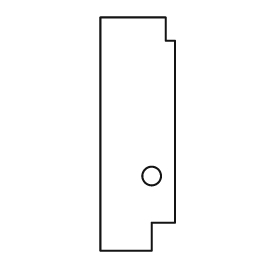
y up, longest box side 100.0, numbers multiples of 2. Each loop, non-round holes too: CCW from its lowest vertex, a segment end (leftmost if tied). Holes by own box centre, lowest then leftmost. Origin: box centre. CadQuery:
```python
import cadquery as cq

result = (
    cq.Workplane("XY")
    .moveTo(-16.0, -50.0)
    .lineTo(6.0, -50.0)
    .lineTo(6.0, -38.0)
    .lineTo(16.0, -38.0)
    .lineTo(16.0, 40.0)
    .lineTo(12.0, 40.0)
    .lineTo(12.0, 50.0)
    .lineTo(-16.0, 50.0)
    .close()
    .moveTo(6.0, -18.0)
    .circle(4.0)
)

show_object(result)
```